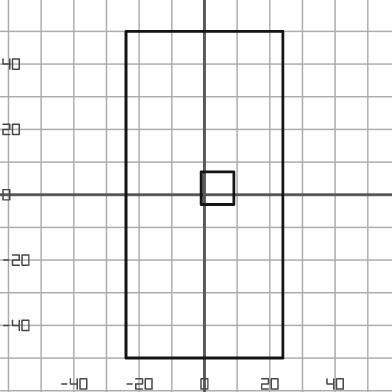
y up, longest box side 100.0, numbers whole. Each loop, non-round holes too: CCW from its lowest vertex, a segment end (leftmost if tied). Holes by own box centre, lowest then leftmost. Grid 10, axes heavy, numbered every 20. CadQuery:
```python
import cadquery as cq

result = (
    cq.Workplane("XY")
    .moveTo(-24.0, -50.0)
    .lineTo(24.0, -50.0)
    .lineTo(24.0, 50.0)
    .lineTo(-24.0, 50.0)
    .close()
    .moveTo(-1.0, -3.0)
    .lineTo(9.0, -3.0)
    .lineTo(9.0, 7.0)
    .lineTo(-1.0, 7.0)
    .close()
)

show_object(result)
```